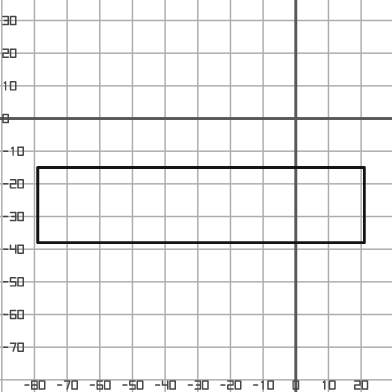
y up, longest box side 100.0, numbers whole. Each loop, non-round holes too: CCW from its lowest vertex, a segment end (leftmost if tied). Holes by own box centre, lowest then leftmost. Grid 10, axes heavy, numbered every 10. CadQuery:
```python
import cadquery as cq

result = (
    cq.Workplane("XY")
    .moveTo(-79.0, -38.0)
    .lineTo(21.0, -38.0)
    .lineTo(21.0, -15.0)
    .lineTo(-79.0, -15.0)
    .close()
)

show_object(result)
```